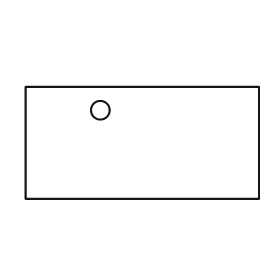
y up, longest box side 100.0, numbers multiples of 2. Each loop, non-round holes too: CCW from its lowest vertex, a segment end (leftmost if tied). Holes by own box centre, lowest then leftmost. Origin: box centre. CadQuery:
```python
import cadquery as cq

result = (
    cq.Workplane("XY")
    .moveTo(-50.0, -24.0)
    .lineTo(50.0, -24.0)
    .lineTo(50.0, 24.0)
    .lineTo(-50.0, 24.0)
    .close()
    .moveTo(-18.0, 14.0)
    .circle(4.0)
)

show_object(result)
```